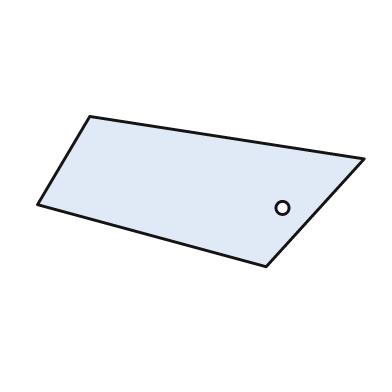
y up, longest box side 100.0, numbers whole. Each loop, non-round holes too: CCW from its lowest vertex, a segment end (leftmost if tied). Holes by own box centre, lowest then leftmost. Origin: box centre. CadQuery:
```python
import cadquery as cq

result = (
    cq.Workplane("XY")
    .moveTo(20.0, -23.0)
    .lineTo(50.0, 10.0)
    .lineTo(-34.0, 23.0)
    .lineTo(-50.0, -4.0)
    .close()
    .moveTo(25.0, -5.0)
    .circle(2.0)
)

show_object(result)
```